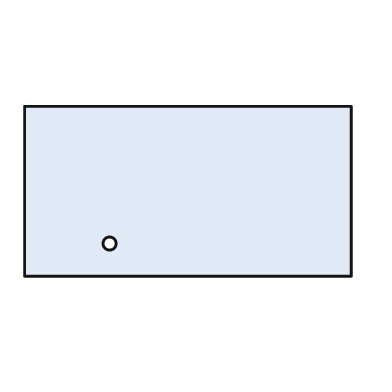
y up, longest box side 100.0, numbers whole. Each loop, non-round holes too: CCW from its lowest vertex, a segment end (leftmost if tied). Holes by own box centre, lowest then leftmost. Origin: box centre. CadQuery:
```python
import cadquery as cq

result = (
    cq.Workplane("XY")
    .moveTo(-50.0, -26.0)
    .lineTo(50.0, -26.0)
    .lineTo(50.0, 26.0)
    .lineTo(-50.0, 26.0)
    .close()
    .moveTo(-24.0, -16.0)
    .circle(2.0)
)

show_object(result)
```